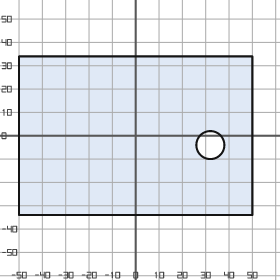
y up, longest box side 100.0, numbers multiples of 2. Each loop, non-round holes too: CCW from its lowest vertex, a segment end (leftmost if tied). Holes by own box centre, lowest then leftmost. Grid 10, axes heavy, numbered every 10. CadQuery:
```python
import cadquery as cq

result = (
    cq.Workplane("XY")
    .moveTo(-50.0, -34.0)
    .lineTo(50.0, -34.0)
    .lineTo(50.0, 34.0)
    .lineTo(-50.0, 34.0)
    .close()
    .moveTo(32.0, -4.0)
    .circle(6.0)
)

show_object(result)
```